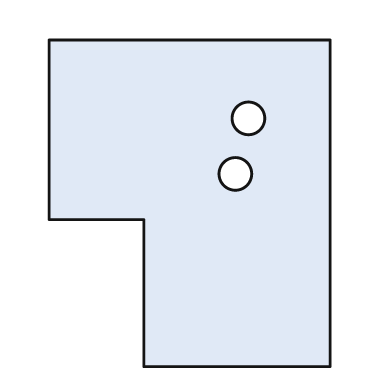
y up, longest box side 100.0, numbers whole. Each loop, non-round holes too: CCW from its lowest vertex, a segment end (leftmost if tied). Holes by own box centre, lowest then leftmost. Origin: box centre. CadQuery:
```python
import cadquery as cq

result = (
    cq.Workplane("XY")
    .moveTo(-14.0, -50.0)
    .lineTo(43.0, -50.0)
    .lineTo(43.0, 50.0)
    .lineTo(-43.0, 50.0)
    .lineTo(-43.0, -5.0)
    .lineTo(-14.0, -5.0)
    .close()
    .moveTo(14.0, 9.0)
    .circle(5.0)
    .moveTo(18.0, 26.0)
    .circle(5.0)
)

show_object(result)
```